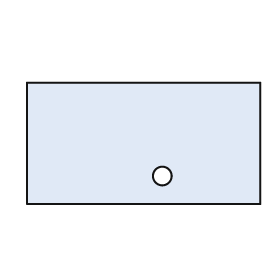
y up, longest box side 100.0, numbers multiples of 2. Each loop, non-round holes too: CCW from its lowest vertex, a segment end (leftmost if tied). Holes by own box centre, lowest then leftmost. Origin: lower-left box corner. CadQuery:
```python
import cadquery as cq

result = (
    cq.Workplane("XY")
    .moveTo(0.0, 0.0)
    .lineTo(100.0, 0.0)
    .lineTo(100.0, 52.0)
    .lineTo(0.0, 52.0)
    .close()
    .moveTo(58.0, 12.0)
    .circle(4.0)
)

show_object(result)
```